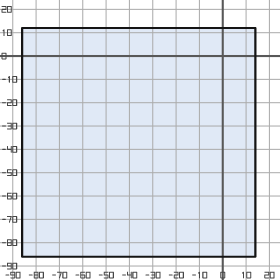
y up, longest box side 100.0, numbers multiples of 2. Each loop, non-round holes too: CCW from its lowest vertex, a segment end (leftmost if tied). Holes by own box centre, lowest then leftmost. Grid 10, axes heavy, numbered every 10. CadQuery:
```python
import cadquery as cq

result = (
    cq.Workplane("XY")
    .moveTo(-86.0, -86.0)
    .lineTo(14.0, -86.0)
    .lineTo(14.0, 12.0)
    .lineTo(-86.0, 12.0)
    .close()
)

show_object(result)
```